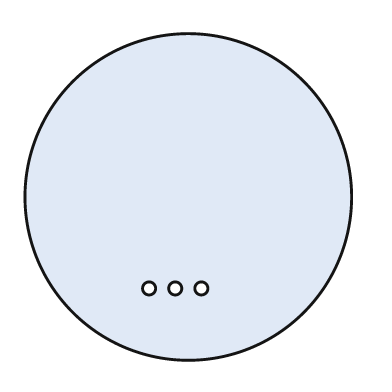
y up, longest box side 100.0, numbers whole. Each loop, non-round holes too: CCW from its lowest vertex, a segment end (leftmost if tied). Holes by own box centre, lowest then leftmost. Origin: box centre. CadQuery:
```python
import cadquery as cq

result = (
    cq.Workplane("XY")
    .moveTo(0.0, 0.0)
    .circle(50.0)
    .moveTo(-12.0, -28.0)
    .circle(2.0)
    .moveTo(-4.0, -28.0)
    .circle(2.0)
    .moveTo(4.0, -28.0)
    .circle(2.0)
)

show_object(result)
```